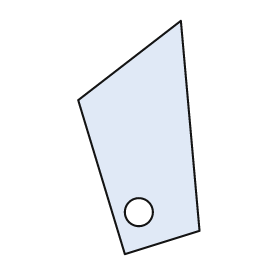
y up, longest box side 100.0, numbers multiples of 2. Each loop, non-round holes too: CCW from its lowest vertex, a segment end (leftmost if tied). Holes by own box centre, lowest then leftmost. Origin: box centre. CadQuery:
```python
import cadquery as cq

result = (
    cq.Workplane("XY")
    .moveTo(-6.0, -50.0)
    .lineTo(26.0, -40.0)
    .lineTo(18.0, 50.0)
    .lineTo(-26.0, 16.0)
    .close()
    .moveTo(0.0, -32.0)
    .circle(6.0)
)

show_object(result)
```